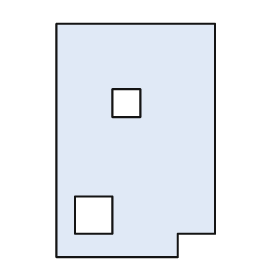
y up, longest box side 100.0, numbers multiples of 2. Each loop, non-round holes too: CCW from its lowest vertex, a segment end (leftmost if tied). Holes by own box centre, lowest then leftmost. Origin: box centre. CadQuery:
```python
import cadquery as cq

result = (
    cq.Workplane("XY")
    .moveTo(-34.0, -50.0)
    .lineTo(18.0, -50.0)
    .lineTo(18.0, -40.0)
    .lineTo(34.0, -40.0)
    .lineTo(34.0, 50.0)
    .lineTo(-34.0, 50.0)
    .close()
    .moveTo(-26.0, -40.0)
    .lineTo(-10.0, -40.0)
    .lineTo(-10.0, -24.0)
    .lineTo(-26.0, -24.0)
    .close()
    .moveTo(-10.0, 10.0)
    .lineTo(2.0, 10.0)
    .lineTo(2.0, 22.0)
    .lineTo(-10.0, 22.0)
    .close()
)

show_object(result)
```